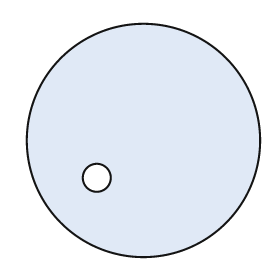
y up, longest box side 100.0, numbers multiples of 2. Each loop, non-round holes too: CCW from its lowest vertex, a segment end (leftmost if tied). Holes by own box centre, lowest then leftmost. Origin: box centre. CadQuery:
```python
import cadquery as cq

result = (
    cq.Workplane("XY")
    .moveTo(0.0, 0.0)
    .circle(50.0)
    .moveTo(-20.0, -16.0)
    .circle(6.0)
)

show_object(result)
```